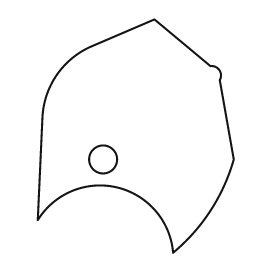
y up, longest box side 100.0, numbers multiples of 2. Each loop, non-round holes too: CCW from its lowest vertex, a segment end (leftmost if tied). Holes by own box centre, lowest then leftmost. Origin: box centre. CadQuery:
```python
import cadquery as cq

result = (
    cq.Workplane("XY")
    .moveTo(16.0, -50.0)
    .threePointArc((32.0, -32.0), (42.0, -10.0))
    .lineTo(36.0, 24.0)
    .threePointArc((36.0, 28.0), (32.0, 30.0))
    .lineTo(8.0, 50.0)
    .lineTo(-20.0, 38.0)
    .threePointArc((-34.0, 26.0), (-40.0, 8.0))
    .lineTo(-42.0, -36.0)
    .threePointArc((-8.0, -22.0), (16.0, -50.0))
    .close()
    .moveTo(-14.0, -10.0)
    .circle(6.0)
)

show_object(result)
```